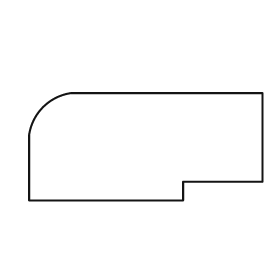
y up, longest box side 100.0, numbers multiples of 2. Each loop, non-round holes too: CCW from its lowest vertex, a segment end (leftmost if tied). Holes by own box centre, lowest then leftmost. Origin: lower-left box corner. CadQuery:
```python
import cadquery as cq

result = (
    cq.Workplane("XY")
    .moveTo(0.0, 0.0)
    .lineTo(66.0, 0.0)
    .lineTo(66.0, 8.0)
    .lineTo(100.0, 8.0)
    .lineTo(100.0, 46.0)
    .lineTo(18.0, 46.0)
    .threePointArc((6.0, 40.0), (0.0, 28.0))
    .close()
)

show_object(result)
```